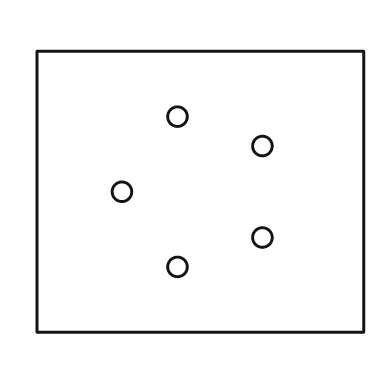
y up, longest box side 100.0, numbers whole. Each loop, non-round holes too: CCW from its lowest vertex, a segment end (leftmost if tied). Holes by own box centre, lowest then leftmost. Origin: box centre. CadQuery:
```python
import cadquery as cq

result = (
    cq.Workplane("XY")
    .moveTo(-50.0, -43.0)
    .lineTo(50.0, -43.0)
    .lineTo(50.0, 43.0)
    .lineTo(-50.0, 43.0)
    .close()
    .moveTo(-7.0, -23.0)
    .circle(3.0)
    .moveTo(19.0, -14.0)
    .circle(3.0)
    .moveTo(-24.0, 0.0)
    .circle(3.0)
    .moveTo(19.0, 14.0)
    .circle(3.0)
    .moveTo(-7.0, 23.0)
    .circle(3.0)
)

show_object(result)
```